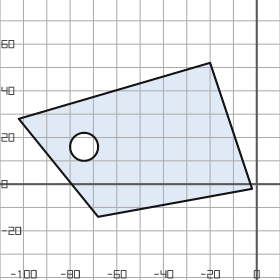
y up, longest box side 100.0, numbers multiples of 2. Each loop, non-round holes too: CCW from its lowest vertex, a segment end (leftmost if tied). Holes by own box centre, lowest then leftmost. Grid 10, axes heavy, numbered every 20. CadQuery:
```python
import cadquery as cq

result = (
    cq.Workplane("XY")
    .moveTo(-68.0, -14.0)
    .lineTo(-2.0, -2.0)
    .lineTo(-20.0, 52.0)
    .lineTo(-102.0, 28.0)
    .close()
    .moveTo(-74.0, 16.0)
    .circle(6.0)
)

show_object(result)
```